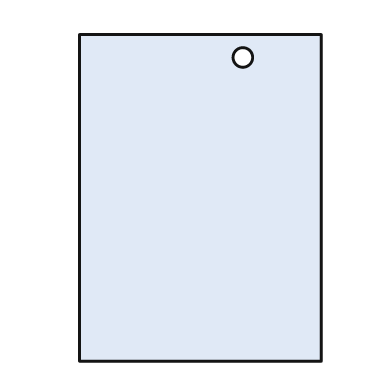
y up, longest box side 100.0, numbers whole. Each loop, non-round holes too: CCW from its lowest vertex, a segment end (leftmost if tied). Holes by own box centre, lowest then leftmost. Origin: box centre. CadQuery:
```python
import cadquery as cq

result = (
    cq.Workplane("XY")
    .moveTo(-37.0, -50.0)
    .lineTo(37.0, -50.0)
    .lineTo(37.0, 50.0)
    .lineTo(-37.0, 50.0)
    .close()
    .moveTo(13.0, 43.0)
    .circle(3.0)
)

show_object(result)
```